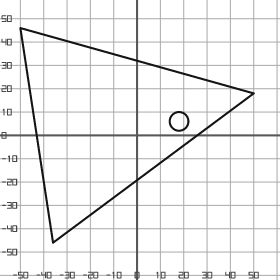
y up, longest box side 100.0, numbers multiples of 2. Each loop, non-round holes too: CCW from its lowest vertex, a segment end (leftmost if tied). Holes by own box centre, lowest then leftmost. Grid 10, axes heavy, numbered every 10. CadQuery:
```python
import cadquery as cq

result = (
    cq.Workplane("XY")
    .moveTo(-36.0, -46.0)
    .lineTo(50.0, 18.0)
    .lineTo(-50.0, 46.0)
    .close()
    .moveTo(18.0, 6.0)
    .circle(4.0)
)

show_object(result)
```